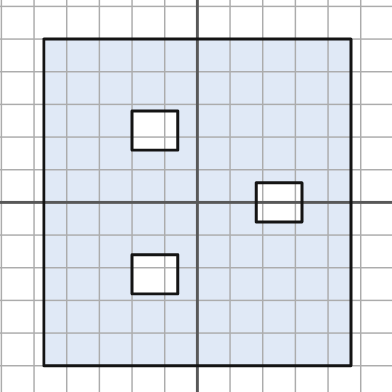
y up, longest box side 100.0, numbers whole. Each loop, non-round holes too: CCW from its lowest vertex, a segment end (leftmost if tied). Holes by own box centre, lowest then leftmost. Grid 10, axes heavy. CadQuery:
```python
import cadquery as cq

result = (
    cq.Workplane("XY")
    .moveTo(-47.0, -50.0)
    .lineTo(47.0, -50.0)
    .lineTo(47.0, 50.0)
    .lineTo(-47.0, 50.0)
    .close()
    .moveTo(-20.0, -28.0)
    .lineTo(-6.0, -28.0)
    .lineTo(-6.0, -16.0)
    .lineTo(-20.0, -16.0)
    .close()
    .moveTo(18.0, -6.0)
    .lineTo(32.0, -6.0)
    .lineTo(32.0, 6.0)
    .lineTo(18.0, 6.0)
    .close()
    .moveTo(-20.0, 16.0)
    .lineTo(-6.0, 16.0)
    .lineTo(-6.0, 28.0)
    .lineTo(-20.0, 28.0)
    .close()
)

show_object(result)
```